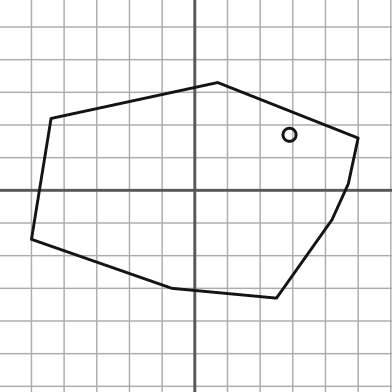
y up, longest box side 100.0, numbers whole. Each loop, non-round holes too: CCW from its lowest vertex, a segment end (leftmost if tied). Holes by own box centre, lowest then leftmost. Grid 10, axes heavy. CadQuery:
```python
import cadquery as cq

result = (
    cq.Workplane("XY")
    .moveTo(25.0, -33.0)
    .lineTo(42.0, -9.0)
    .lineTo(47.0, 2.0)
    .lineTo(50.0, 16.0)
    .lineTo(7.0, 33.0)
    .lineTo(-44.0, 22.0)
    .lineTo(-50.0, -15.0)
    .lineTo(-7.0, -30.0)
    .close()
    .moveTo(29.0, 17.0)
    .circle(2.0)
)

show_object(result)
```